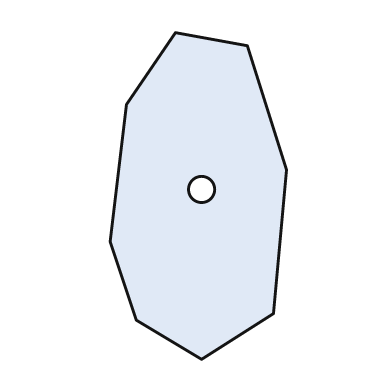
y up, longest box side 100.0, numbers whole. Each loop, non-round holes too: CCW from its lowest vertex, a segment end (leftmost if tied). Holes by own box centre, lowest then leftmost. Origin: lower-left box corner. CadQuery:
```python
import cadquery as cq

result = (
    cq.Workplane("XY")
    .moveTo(28.0, 0.0)
    .lineTo(50.0, 14.0)
    .lineTo(54.0, 58.0)
    .lineTo(42.0, 96.0)
    .lineTo(20.0, 100.0)
    .lineTo(5.0, 78.0)
    .lineTo(0.0, 36.0)
    .lineTo(8.0, 12.0)
    .close()
    .moveTo(28.0, 52.0)
    .circle(4.0)
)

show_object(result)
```